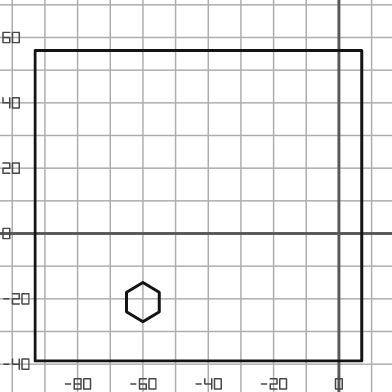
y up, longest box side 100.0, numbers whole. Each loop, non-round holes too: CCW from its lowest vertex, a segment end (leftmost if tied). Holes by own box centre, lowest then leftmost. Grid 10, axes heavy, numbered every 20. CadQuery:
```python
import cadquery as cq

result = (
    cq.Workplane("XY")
    .moveTo(-93.0, -39.0)
    .lineTo(7.0, -39.0)
    .lineTo(7.0, 56.0)
    .lineTo(-93.0, 56.0)
    .close()
    .moveTo(-60.0, -27.0)
    .lineTo(-55.0, -24.0)
    .lineTo(-55.0, -18.0)
    .lineTo(-60.0, -15.0)
    .lineTo(-65.0, -18.0)
    .lineTo(-65.0, -24.0)
    .close()
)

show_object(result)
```